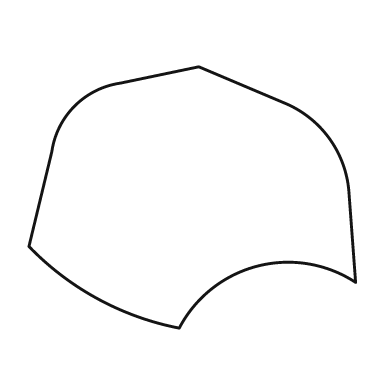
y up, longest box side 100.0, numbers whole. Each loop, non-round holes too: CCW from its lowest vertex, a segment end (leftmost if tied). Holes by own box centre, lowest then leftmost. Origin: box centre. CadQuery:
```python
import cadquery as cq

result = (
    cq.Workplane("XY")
    .moveTo(-4.0, -40.0)
    .threePointArc((20.0, -21.0), (50.0, -26.0))
    .lineTo(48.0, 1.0)
    .threePointArc((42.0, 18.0), (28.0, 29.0))
    .lineTo(2.0, 40.0)
    .lineTo(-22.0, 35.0)
    .threePointArc((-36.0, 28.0), (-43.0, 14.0))
    .lineTo(-50.0, -15.0)
    .threePointArc((-29.0, -31.0), (-4.0, -40.0))
    .close()
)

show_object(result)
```